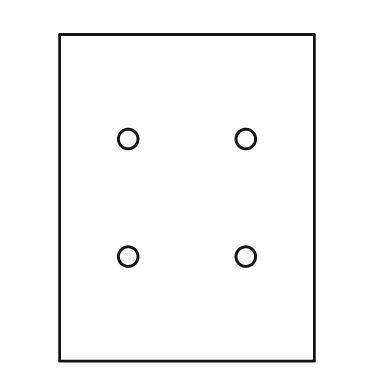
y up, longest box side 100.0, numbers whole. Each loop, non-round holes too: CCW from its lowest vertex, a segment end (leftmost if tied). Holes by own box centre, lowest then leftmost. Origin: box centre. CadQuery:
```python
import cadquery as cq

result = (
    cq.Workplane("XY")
    .moveTo(-39.0, -50.0)
    .lineTo(39.0, -50.0)
    .lineTo(39.0, 50.0)
    .lineTo(-39.0, 50.0)
    .close()
    .moveTo(-18.0, -18.0)
    .circle(3.0)
    .moveTo(18.0, -18.0)
    .circle(3.0)
    .moveTo(-18.0, 18.0)
    .circle(3.0)
    .moveTo(18.0, 18.0)
    .circle(3.0)
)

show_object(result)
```